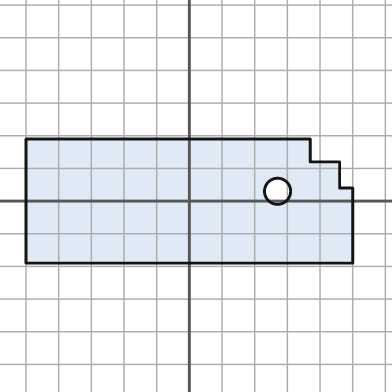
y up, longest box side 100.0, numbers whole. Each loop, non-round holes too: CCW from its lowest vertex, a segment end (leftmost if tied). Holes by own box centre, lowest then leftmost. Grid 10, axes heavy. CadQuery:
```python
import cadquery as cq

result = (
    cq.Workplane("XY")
    .moveTo(-50.0, -19.0)
    .lineTo(50.0, -19.0)
    .lineTo(50.0, 4.0)
    .lineTo(46.0, 4.0)
    .lineTo(46.0, 12.0)
    .lineTo(37.0, 12.0)
    .lineTo(37.0, 19.0)
    .lineTo(-50.0, 19.0)
    .close()
    .moveTo(27.0, 3.0)
    .circle(4.0)
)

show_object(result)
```